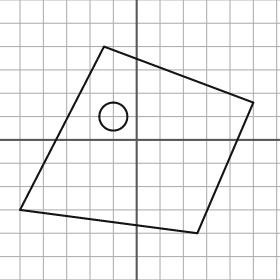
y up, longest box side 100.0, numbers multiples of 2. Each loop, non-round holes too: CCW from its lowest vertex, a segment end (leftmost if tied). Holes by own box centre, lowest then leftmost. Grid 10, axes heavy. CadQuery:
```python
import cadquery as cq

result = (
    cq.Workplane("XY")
    .moveTo(26.0, -40.0)
    .lineTo(50.0, 16.0)
    .lineTo(-14.0, 40.0)
    .lineTo(-50.0, -30.0)
    .close()
    .moveTo(-10.0, 10.0)
    .circle(6.0)
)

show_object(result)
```